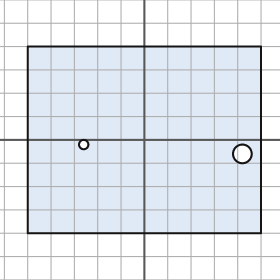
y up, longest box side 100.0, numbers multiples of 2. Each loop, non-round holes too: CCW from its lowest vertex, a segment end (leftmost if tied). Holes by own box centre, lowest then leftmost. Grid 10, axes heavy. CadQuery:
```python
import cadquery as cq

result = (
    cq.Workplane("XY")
    .moveTo(-50.0, -40.0)
    .lineTo(50.0, -40.0)
    .lineTo(50.0, 40.0)
    .lineTo(-50.0, 40.0)
    .close()
    .moveTo(42.0, -6.0)
    .circle(4.0)
    .moveTo(-26.0, -2.0)
    .circle(2.0)
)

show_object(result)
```